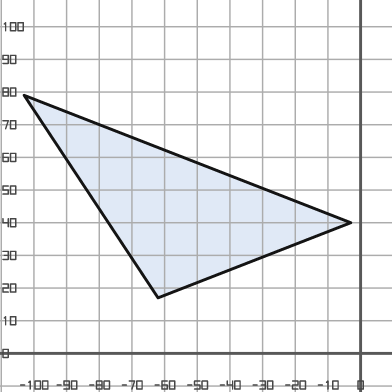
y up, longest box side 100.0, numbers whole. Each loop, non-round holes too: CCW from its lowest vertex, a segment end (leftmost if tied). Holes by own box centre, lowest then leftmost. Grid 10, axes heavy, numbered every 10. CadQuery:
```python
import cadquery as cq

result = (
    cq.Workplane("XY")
    .moveTo(-62.0, 17.0)
    .lineTo(-3.0, 40.0)
    .lineTo(-103.0, 79.0)
    .close()
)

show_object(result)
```